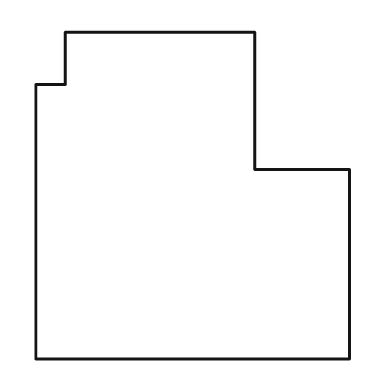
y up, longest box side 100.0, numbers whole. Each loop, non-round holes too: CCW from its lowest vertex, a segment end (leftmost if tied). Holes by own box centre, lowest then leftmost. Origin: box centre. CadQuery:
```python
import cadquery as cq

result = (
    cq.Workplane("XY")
    .moveTo(-48.0, -50.0)
    .lineTo(48.0, -50.0)
    .lineTo(48.0, 8.0)
    .lineTo(19.0, 8.0)
    .lineTo(19.0, 50.0)
    .lineTo(-39.0, 50.0)
    .lineTo(-39.0, 34.0)
    .lineTo(-48.0, 34.0)
    .close()
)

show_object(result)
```